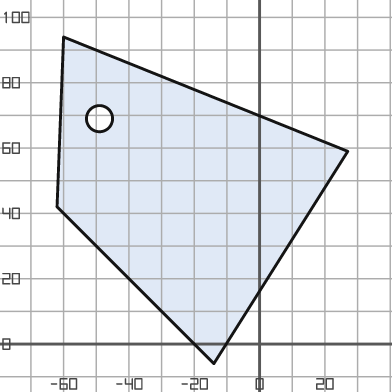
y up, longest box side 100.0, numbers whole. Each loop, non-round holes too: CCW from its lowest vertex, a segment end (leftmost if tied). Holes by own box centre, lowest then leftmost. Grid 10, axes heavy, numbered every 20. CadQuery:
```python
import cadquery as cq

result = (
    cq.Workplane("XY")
    .moveTo(-14.0, -6.0)
    .lineTo(27.0, 59.0)
    .lineTo(-60.0, 94.0)
    .lineTo(-62.0, 42.0)
    .close()
    .moveTo(-49.0, 69.0)
    .circle(4.0)
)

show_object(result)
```